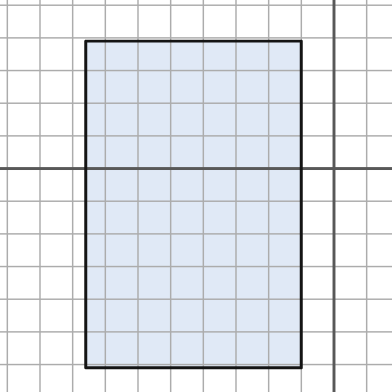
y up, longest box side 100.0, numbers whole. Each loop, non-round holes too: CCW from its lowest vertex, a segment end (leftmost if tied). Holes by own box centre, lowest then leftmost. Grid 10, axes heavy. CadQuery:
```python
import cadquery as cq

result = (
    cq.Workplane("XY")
    .moveTo(-76.0, -61.0)
    .lineTo(-10.0, -61.0)
    .lineTo(-10.0, 39.0)
    .lineTo(-76.0, 39.0)
    .close()
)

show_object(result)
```